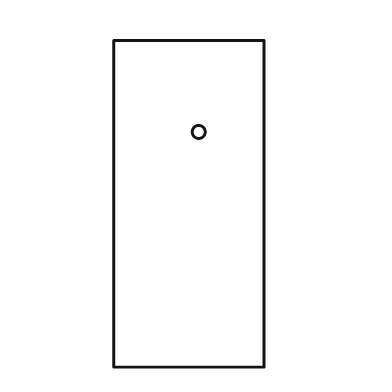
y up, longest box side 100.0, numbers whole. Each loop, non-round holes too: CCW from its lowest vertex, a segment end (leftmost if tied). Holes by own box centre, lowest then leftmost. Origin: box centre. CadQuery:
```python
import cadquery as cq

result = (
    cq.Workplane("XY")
    .moveTo(-23.0, -50.0)
    .lineTo(23.0, -50.0)
    .lineTo(23.0, 50.0)
    .lineTo(-23.0, 50.0)
    .close()
    .moveTo(3.0, 22.0)
    .circle(2.0)
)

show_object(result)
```